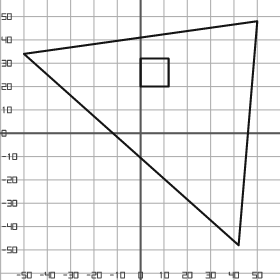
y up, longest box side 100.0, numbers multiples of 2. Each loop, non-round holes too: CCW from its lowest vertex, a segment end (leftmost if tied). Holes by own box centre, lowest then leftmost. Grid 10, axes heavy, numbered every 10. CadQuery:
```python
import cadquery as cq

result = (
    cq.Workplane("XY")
    .moveTo(42.0, -48.0)
    .lineTo(50.0, 48.0)
    .lineTo(-50.0, 34.0)
    .close()
    .moveTo(0.0, 20.0)
    .lineTo(12.0, 20.0)
    .lineTo(12.0, 32.0)
    .lineTo(0.0, 32.0)
    .close()
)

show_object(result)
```